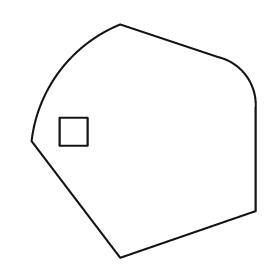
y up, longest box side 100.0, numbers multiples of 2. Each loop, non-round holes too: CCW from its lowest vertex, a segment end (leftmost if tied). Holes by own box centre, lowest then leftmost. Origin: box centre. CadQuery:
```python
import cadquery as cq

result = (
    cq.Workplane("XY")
    .moveTo(-10.0, -50.0)
    .lineTo(48.0, -30.0)
    .lineTo(48.0, 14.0)
    .threePointArc((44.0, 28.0), (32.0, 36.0))
    .lineTo(-10.0, 50.0)
    .threePointArc((-36.0, 30.0), (-48.0, 0.0))
    .close()
    .moveTo(-36.0, -2.0)
    .lineTo(-24.0, -2.0)
    .lineTo(-24.0, 10.0)
    .lineTo(-36.0, 10.0)
    .close()
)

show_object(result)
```